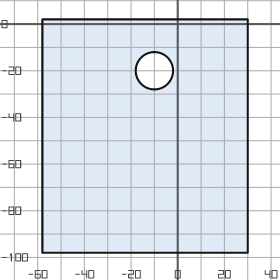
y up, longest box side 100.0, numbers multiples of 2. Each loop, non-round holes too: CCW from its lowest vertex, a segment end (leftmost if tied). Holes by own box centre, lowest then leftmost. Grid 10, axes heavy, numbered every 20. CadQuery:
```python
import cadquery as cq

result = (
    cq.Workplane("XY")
    .moveTo(-58.0, -98.0)
    .lineTo(30.0, -98.0)
    .lineTo(30.0, 2.0)
    .lineTo(-58.0, 2.0)
    .close()
    .moveTo(-10.0, -20.0)
    .circle(8.0)
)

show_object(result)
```